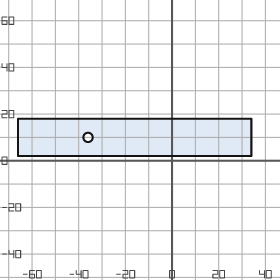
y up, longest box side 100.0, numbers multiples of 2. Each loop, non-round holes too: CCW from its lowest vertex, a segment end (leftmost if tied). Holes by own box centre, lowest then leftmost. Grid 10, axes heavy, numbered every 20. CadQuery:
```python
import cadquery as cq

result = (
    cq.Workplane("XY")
    .moveTo(-66.0, 2.0)
    .lineTo(34.0, 2.0)
    .lineTo(34.0, 18.0)
    .lineTo(-66.0, 18.0)
    .close()
    .moveTo(-36.0, 10.0)
    .circle(2.0)
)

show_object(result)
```